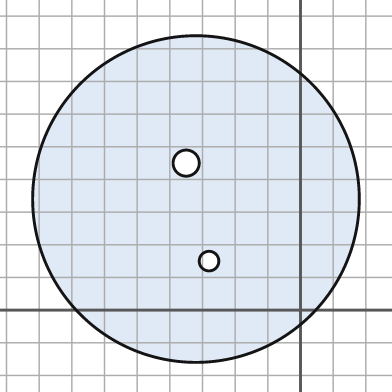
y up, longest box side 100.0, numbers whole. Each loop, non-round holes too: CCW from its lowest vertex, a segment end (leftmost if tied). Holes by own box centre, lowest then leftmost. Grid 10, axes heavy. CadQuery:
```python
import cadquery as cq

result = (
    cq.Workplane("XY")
    .moveTo(-32.0, 34.0)
    .circle(50.0)
    .moveTo(-28.0, 15.0)
    .circle(3.0)
    .moveTo(-35.0, 45.0)
    .circle(4.0)
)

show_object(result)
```